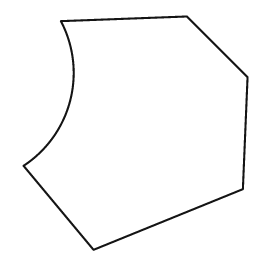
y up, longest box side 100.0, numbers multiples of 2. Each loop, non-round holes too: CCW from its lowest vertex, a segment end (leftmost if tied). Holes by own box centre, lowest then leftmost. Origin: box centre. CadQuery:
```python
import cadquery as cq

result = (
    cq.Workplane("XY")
    .moveTo(-18.0, -50.0)
    .lineTo(46.0, -24.0)
    .lineTo(48.0, 24.0)
    .lineTo(22.0, 50.0)
    .lineTo(-32.0, 48.0)
    .threePointArc((-28.0, 14.0), (-48.0, -14.0))
    .close()
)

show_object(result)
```